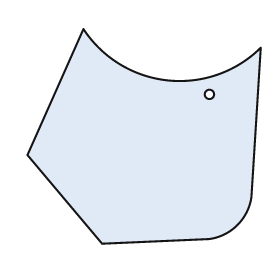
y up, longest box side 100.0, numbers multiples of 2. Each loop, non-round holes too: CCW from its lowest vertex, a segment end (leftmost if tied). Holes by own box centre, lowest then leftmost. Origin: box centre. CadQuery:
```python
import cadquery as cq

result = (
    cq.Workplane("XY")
    .moveTo(-18.0, -46.0)
    .lineTo(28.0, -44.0)
    .threePointArc((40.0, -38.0), (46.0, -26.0))
    .lineTo(50.0, 38.0)
    .threePointArc((10.0, 24.0), (-26.0, 46.0))
    .lineTo(-50.0, -8.0)
    .close()
    .moveTo(28.0, 18.0)
    .circle(2.0)
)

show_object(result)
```